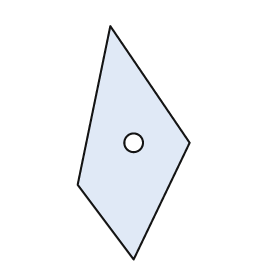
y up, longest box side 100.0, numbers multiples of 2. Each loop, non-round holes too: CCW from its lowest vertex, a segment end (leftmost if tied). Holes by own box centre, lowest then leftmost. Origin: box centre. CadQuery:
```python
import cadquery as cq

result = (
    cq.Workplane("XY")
    .moveTo(0.0, -50.0)
    .lineTo(24.0, 0.0)
    .lineTo(-10.0, 50.0)
    .lineTo(-24.0, -18.0)
    .close()
    .moveTo(0.0, 0.0)
    .circle(4.0)
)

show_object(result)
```